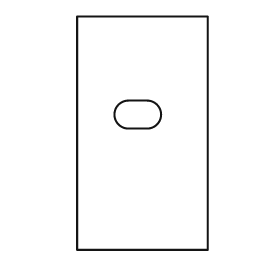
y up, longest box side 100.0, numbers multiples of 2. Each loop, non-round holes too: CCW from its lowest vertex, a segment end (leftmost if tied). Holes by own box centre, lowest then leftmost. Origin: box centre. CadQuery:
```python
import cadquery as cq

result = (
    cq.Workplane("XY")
    .moveTo(-28.0, -50.0)
    .lineTo(28.0, -50.0)
    .lineTo(28.0, 50.0)
    .lineTo(-28.0, 50.0)
    .close()
    .moveTo(-6.0, 2.0)
    .lineTo(2.0, 2.0)
    .threePointArc((8.0, 8.0), (2.0, 14.0))
    .lineTo(-6.0, 14.0)
    .threePointArc((-12.0, 8.0), (-6.0, 2.0))
    .close()
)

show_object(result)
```